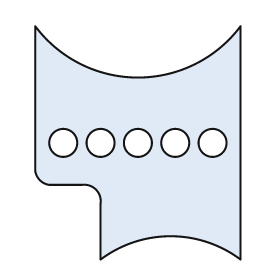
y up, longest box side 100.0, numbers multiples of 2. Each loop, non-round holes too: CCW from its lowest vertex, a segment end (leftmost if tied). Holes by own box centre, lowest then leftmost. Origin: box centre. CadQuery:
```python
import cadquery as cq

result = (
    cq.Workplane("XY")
    .moveTo(-16.0, -50.0)
    .threePointArc((14.0, -40.0), (44.0, -50.0))
    .lineTo(44.0, 50.0)
    .threePointArc((0.0, 28.0), (-44.0, 50.0))
    .lineTo(-44.0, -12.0)
    .threePointArc((-42.0, -16.0), (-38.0, -18.0))
    .lineTo(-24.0, -18.0)
    .threePointArc((-18.0, -20.0), (-16.0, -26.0))
    .close()
    .moveTo(-32.0, 0.0)
    .circle(6.0)
    .moveTo(-16.0, 0.0)
    .circle(6.0)
    .moveTo(0.0, 0.0)
    .circle(6.0)
    .moveTo(16.0, 0.0)
    .circle(6.0)
    .moveTo(32.0, 0.0)
    .circle(6.0)
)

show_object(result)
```